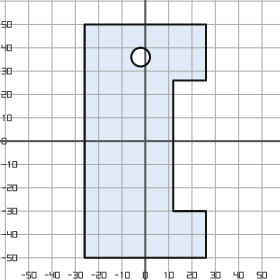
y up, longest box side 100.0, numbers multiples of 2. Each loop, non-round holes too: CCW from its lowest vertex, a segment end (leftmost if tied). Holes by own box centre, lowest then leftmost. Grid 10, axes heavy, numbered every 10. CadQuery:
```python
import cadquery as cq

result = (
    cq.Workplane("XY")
    .moveTo(-26.0, -50.0)
    .lineTo(26.0, -50.0)
    .lineTo(26.0, -30.0)
    .lineTo(12.0, -30.0)
    .lineTo(12.0, 26.0)
    .lineTo(26.0, 26.0)
    .lineTo(26.0, 50.0)
    .lineTo(-26.0, 50.0)
    .close()
    .moveTo(-2.0, 36.0)
    .circle(4.0)
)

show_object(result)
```